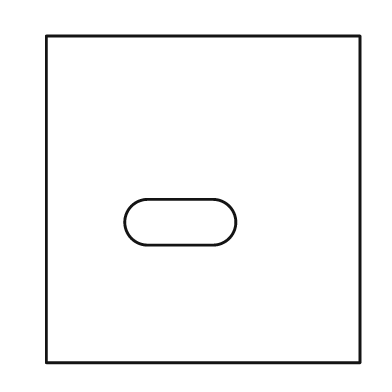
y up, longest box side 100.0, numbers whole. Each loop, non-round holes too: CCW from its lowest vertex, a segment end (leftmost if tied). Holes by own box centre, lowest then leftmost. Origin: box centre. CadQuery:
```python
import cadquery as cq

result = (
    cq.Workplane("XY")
    .moveTo(-48.0, -50.0)
    .lineTo(48.0, -50.0)
    .lineTo(48.0, 50.0)
    .lineTo(-48.0, 50.0)
    .close()
    .moveTo(-17.0, -14.0)
    .lineTo(3.0, -14.0)
    .threePointArc((10.0, -7.0), (3.0, 0.0))
    .lineTo(-17.0, 0.0)
    .threePointArc((-24.0, -7.0), (-17.0, -14.0))
    .close()
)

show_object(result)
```